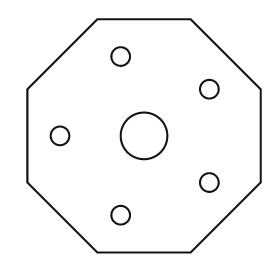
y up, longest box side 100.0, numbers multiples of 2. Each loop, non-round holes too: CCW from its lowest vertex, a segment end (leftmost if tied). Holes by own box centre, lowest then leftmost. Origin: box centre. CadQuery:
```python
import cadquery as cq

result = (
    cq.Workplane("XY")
    .moveTo(-20.0, -50.0)
    .lineTo(20.0, -50.0)
    .lineTo(50.0, -20.0)
    .lineTo(50.0, 20.0)
    .lineTo(20.0, 50.0)
    .lineTo(-20.0, 50.0)
    .lineTo(-50.0, 20.0)
    .lineTo(-50.0, -20.0)
    .close()
    .moveTo(-10.0, -34.0)
    .circle(4.0)
    .moveTo(28.0, -20.0)
    .circle(4.0)
    .moveTo(-36.0, 0.0)
    .circle(4.0)
    .moveTo(0.0, 0.0)
    .circle(10.0)
    .moveTo(28.0, 20.0)
    .circle(4.0)
    .moveTo(-10.0, 34.0)
    .circle(4.0)
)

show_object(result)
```